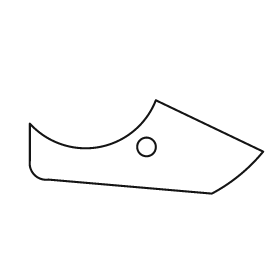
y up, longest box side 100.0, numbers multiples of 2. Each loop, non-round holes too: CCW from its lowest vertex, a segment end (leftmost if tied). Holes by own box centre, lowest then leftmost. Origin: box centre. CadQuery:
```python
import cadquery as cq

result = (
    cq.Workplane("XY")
    .moveTo(28.0, -20.0)
    .threePointArc((40.0, -12.0), (50.0, -2.0))
    .lineTo(4.0, 20.0)
    .threePointArc((-20.0, 0.0), (-50.0, 10.0))
    .lineTo(-50.0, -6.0)
    .threePointArc((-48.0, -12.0), (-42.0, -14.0))
    .close()
    .moveTo(0.0, 0.0)
    .circle(4.0)
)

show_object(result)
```